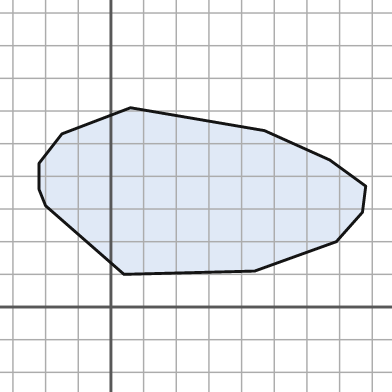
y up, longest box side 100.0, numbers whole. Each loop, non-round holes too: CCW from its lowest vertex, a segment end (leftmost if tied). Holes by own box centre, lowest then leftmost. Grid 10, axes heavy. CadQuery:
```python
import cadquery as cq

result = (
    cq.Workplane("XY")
    .moveTo(4.0, 10.0)
    .lineTo(44.0, 11.0)
    .lineTo(69.0, 20.0)
    .lineTo(77.0, 29.0)
    .lineTo(78.0, 37.0)
    .lineTo(67.0, 45.0)
    .lineTo(47.0, 54.0)
    .lineTo(6.0, 61.0)
    .lineTo(-15.0, 53.0)
    .lineTo(-22.0, 44.0)
    .lineTo(-22.0, 36.0)
    .lineTo(-20.0, 31.0)
    .close()
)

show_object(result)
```